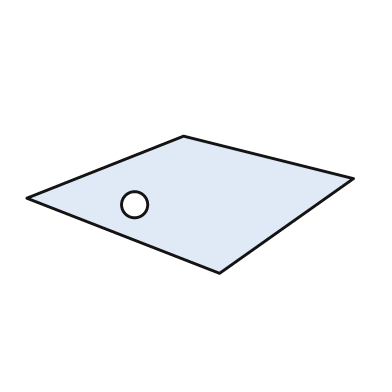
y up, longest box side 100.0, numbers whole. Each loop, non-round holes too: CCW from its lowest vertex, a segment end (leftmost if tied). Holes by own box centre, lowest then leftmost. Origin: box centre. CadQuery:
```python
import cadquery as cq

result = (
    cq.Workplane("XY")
    .moveTo(9.0, -21.0)
    .lineTo(50.0, 8.0)
    .lineTo(-2.0, 21.0)
    .lineTo(-50.0, 2.0)
    .close()
    .moveTo(-17.0, 0.0)
    .circle(4.0)
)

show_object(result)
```